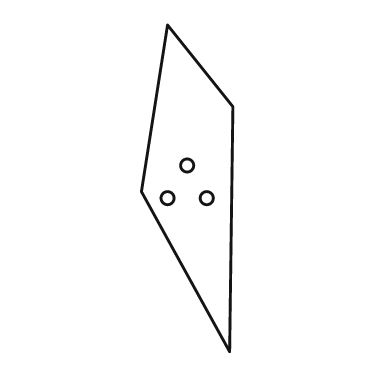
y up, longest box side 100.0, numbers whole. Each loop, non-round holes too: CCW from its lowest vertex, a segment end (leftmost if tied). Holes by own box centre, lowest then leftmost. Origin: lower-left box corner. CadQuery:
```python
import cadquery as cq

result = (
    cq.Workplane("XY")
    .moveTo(27.0, 0.0)
    .lineTo(28.0, 75.0)
    .lineTo(8.0, 100.0)
    .lineTo(0.0, 49.0)
    .close()
    .moveTo(8.0, 47.0)
    .circle(2.0)
    .moveTo(20.0, 47.0)
    .circle(2.0)
    .moveTo(14.0, 57.0)
    .circle(2.0)
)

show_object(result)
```